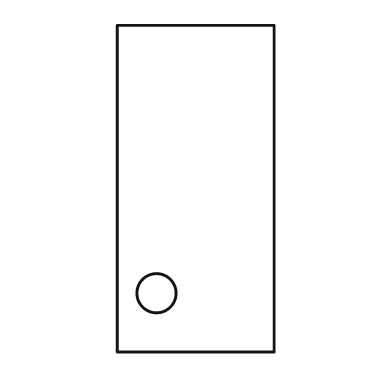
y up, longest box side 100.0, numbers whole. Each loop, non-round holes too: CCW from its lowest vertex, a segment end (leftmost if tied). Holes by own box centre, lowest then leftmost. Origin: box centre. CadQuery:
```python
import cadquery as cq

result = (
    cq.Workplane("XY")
    .moveTo(-24.0, -50.0)
    .lineTo(24.0, -50.0)
    .lineTo(24.0, 50.0)
    .lineTo(-24.0, 50.0)
    .close()
    .moveTo(-12.0, -32.0)
    .circle(6.0)
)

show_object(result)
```